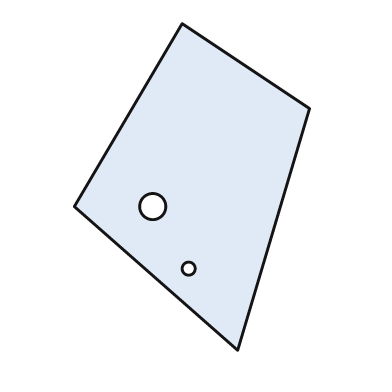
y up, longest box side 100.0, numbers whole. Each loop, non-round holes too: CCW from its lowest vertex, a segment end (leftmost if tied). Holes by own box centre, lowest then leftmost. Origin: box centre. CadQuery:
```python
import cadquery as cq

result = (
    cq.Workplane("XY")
    .moveTo(14.0, -50.0)
    .lineTo(36.0, 24.0)
    .lineTo(-3.0, 50.0)
    .lineTo(-36.0, -6.0)
    .close()
    .moveTo(-1.0, -25.0)
    .circle(2.0)
    .moveTo(-12.0, -6.0)
    .circle(4.0)
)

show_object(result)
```